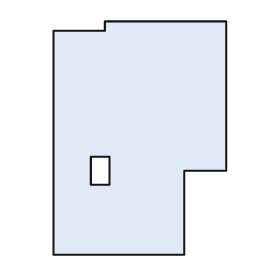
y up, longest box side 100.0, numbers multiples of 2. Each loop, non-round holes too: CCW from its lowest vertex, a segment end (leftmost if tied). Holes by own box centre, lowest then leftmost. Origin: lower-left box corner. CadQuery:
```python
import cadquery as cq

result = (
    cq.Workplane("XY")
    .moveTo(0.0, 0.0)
    .lineTo(56.0, 0.0)
    .lineTo(56.0, 36.0)
    .lineTo(74.0, 36.0)
    .lineTo(74.0, 100.0)
    .lineTo(22.0, 100.0)
    .lineTo(22.0, 96.0)
    .lineTo(0.0, 96.0)
    .close()
    .moveTo(16.0, 30.0)
    .lineTo(24.0, 30.0)
    .lineTo(24.0, 42.0)
    .lineTo(16.0, 42.0)
    .close()
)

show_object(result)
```